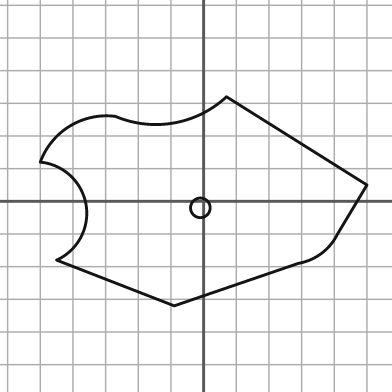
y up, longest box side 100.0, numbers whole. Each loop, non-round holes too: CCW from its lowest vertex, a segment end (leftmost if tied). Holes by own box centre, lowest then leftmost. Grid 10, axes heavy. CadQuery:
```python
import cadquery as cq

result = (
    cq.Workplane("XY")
    .moveTo(-9.0, -32.0)
    .lineTo(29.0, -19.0)
    .threePointArc((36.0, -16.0), (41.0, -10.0))
    .lineTo(50.0, 5.0)
    .lineTo(7.0, 32.0)
    .threePointArc((-9.0, 24.0), (-27.0, 26.0))
    .threePointArc((-41.0, 23.0), (-50.0, 12.0))
    .threePointArc((-36.0, -1.0), (-45.0, -18.0))
    .close()
    .moveTo(-1.0, -2.0)
    .circle(3.0)
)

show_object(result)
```